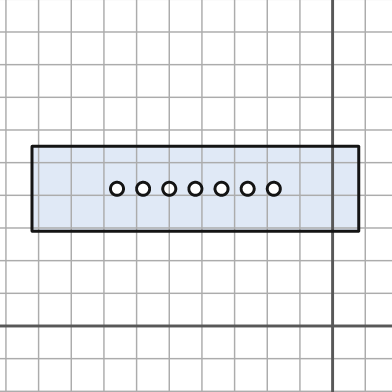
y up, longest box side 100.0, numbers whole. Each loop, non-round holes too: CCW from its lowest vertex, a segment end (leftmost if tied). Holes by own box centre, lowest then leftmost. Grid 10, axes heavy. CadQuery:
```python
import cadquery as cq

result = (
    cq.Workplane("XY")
    .moveTo(-92.0, 29.0)
    .lineTo(8.0, 29.0)
    .lineTo(8.0, 55.0)
    .lineTo(-92.0, 55.0)
    .close()
    .moveTo(-66.0, 42.0)
    .circle(2.0)
    .moveTo(-58.0, 42.0)
    .circle(2.0)
    .moveTo(-50.0, 42.0)
    .circle(2.0)
    .moveTo(-42.0, 42.0)
    .circle(2.0)
    .moveTo(-34.0, 42.0)
    .circle(2.0)
    .moveTo(-26.0, 42.0)
    .circle(2.0)
    .moveTo(-18.0, 42.0)
    .circle(2.0)
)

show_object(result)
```